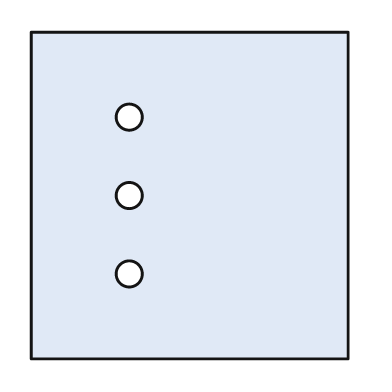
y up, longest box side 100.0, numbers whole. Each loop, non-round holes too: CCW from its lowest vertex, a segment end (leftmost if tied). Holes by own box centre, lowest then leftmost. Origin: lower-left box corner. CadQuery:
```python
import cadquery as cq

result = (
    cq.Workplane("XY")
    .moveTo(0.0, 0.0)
    .lineTo(97.0, 0.0)
    .lineTo(97.0, 100.0)
    .lineTo(0.0, 100.0)
    .close()
    .moveTo(30.0, 26.0)
    .circle(4.0)
    .moveTo(30.0, 50.0)
    .circle(4.0)
    .moveTo(30.0, 74.0)
    .circle(4.0)
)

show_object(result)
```